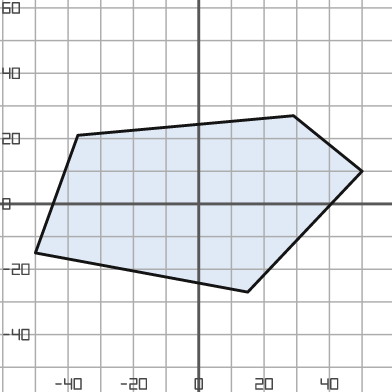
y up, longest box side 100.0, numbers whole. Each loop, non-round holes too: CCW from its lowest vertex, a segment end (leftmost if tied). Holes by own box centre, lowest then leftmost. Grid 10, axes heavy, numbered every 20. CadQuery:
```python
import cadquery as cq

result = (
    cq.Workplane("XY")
    .moveTo(15.0, -27.0)
    .lineTo(50.0, 10.0)
    .lineTo(29.0, 27.0)
    .lineTo(-37.0, 21.0)
    .lineTo(-50.0, -15.0)
    .close()
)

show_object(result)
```